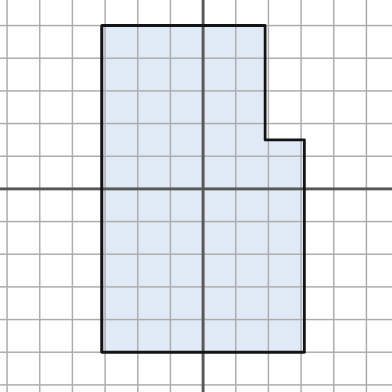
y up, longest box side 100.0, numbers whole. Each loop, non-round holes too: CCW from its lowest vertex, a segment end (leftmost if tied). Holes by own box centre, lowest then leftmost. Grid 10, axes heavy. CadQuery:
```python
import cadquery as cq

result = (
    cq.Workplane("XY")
    .moveTo(-31.0, -50.0)
    .lineTo(31.0, -50.0)
    .lineTo(31.0, 15.0)
    .lineTo(19.0, 15.0)
    .lineTo(19.0, 50.0)
    .lineTo(-31.0, 50.0)
    .close()
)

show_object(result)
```